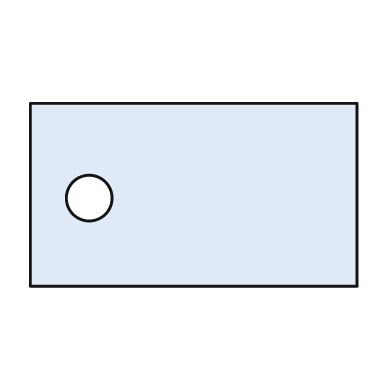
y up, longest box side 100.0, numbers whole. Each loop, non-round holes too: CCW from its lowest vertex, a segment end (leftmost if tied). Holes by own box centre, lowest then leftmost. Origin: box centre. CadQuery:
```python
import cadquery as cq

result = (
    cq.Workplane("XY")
    .moveTo(-50.0, -28.0)
    .lineTo(50.0, -28.0)
    .lineTo(50.0, 28.0)
    .lineTo(-50.0, 28.0)
    .close()
    .moveTo(-32.0, -1.0)
    .circle(7.0)
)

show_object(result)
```